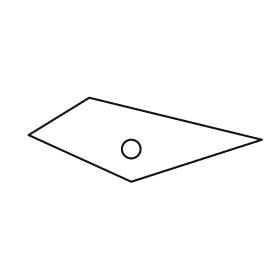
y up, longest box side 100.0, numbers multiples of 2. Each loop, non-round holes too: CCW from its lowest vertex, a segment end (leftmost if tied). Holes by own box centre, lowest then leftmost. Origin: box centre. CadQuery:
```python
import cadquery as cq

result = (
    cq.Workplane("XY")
    .moveTo(-6.0, -18.0)
    .lineTo(50.0, 0.0)
    .lineTo(-24.0, 18.0)
    .lineTo(-50.0, 2.0)
    .close()
    .moveTo(-6.0, -4.0)
    .circle(4.0)
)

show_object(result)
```